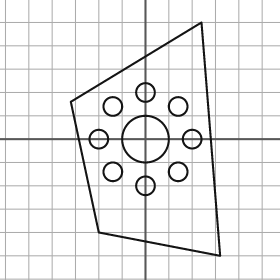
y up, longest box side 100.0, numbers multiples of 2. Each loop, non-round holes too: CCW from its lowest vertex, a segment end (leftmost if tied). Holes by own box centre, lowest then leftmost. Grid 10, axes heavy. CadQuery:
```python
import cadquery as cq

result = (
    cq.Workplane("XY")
    .moveTo(32.0, -50.0)
    .lineTo(24.0, 50.0)
    .lineTo(-32.0, 16.0)
    .lineTo(-20.0, -40.0)
    .close()
    .moveTo(0.0, -20.0)
    .circle(4.0)
    .moveTo(-14.0, -14.0)
    .circle(4.0)
    .moveTo(14.0, -14.0)
    .circle(4.0)
    .moveTo(-20.0, 0.0)
    .circle(4.0)
    .moveTo(0.0, 0.0)
    .circle(10.0)
    .moveTo(20.0, 0.0)
    .circle(4.0)
    .moveTo(-14.0, 14.0)
    .circle(4.0)
    .moveTo(14.0, 14.0)
    .circle(4.0)
    .moveTo(0.0, 20.0)
    .circle(4.0)
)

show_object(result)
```